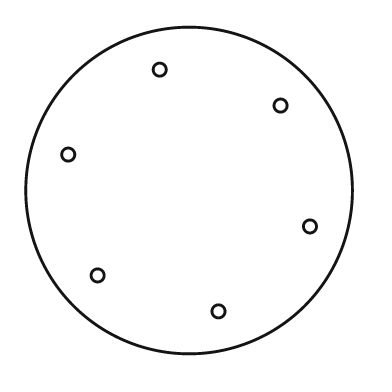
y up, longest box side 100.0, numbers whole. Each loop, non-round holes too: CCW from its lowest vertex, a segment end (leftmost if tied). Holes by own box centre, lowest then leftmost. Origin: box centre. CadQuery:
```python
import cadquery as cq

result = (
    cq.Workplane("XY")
    .moveTo(0.0, 0.0)
    .circle(50.0)
    .moveTo(9.0, -37.0)
    .circle(2.0)
    .moveTo(-28.0, -26.0)
    .circle(2.0)
    .moveTo(37.0, -11.0)
    .circle(2.0)
    .moveTo(-37.0, 11.0)
    .circle(2.0)
    .moveTo(28.0, 26.0)
    .circle(2.0)
    .moveTo(-9.0, 37.0)
    .circle(2.0)
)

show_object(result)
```